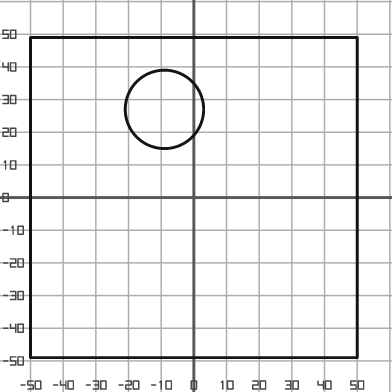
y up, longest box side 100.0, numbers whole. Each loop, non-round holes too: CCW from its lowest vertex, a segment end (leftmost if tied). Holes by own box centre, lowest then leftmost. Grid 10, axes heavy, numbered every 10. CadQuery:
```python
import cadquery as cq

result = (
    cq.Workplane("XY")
    .moveTo(-50.0, -49.0)
    .lineTo(50.0, -49.0)
    .lineTo(50.0, 49.0)
    .lineTo(-50.0, 49.0)
    .close()
    .moveTo(-9.0, 27.0)
    .circle(12.0)
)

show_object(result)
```